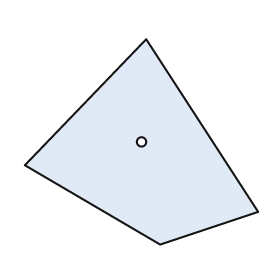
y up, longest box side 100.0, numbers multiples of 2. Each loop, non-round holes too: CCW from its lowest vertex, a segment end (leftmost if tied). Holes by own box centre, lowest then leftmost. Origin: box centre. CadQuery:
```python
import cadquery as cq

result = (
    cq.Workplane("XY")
    .moveTo(8.0, -44.0)
    .lineTo(50.0, -30.0)
    .lineTo(2.0, 44.0)
    .lineTo(-50.0, -10.0)
    .close()
    .moveTo(0.0, 0.0)
    .circle(2.0)
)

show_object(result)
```